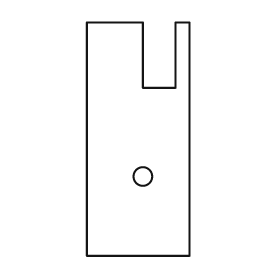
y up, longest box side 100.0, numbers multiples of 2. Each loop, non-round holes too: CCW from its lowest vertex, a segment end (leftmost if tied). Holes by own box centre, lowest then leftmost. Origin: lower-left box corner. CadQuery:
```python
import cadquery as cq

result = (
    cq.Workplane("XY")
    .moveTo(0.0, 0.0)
    .lineTo(44.0, 0.0)
    .lineTo(44.0, 100.0)
    .lineTo(38.0, 100.0)
    .lineTo(38.0, 72.0)
    .lineTo(24.0, 72.0)
    .lineTo(24.0, 100.0)
    .lineTo(0.0, 100.0)
    .close()
    .moveTo(24.0, 34.0)
    .circle(4.0)
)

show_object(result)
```